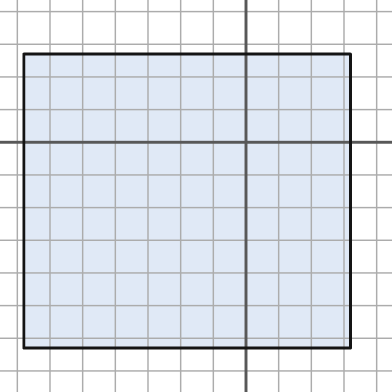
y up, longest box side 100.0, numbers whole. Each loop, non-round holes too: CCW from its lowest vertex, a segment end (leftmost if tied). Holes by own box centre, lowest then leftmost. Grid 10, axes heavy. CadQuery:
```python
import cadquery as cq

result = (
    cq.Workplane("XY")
    .moveTo(-68.0, -63.0)
    .lineTo(32.0, -63.0)
    .lineTo(32.0, 27.0)
    .lineTo(-68.0, 27.0)
    .close()
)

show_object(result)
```